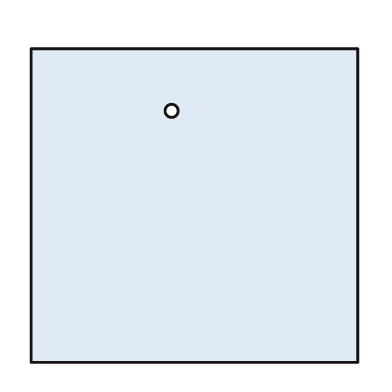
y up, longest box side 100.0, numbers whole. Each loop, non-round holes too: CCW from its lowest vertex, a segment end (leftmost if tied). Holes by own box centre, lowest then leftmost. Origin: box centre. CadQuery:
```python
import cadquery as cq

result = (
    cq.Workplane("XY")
    .moveTo(-50.0, -48.0)
    .lineTo(50.0, -48.0)
    .lineTo(50.0, 48.0)
    .lineTo(-50.0, 48.0)
    .close()
    .moveTo(-7.0, 29.0)
    .circle(2.0)
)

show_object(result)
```